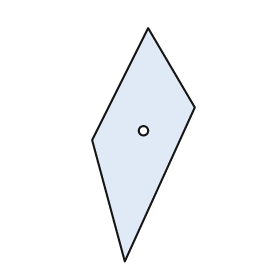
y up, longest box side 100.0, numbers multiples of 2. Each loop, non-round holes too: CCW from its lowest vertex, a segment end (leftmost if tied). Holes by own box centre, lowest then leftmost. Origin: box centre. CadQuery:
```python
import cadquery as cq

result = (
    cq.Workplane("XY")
    .moveTo(-8.0, -50.0)
    .lineTo(22.0, 16.0)
    .lineTo(2.0, 50.0)
    .lineTo(-22.0, 2.0)
    .close()
    .moveTo(0.0, 6.0)
    .circle(2.0)
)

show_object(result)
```